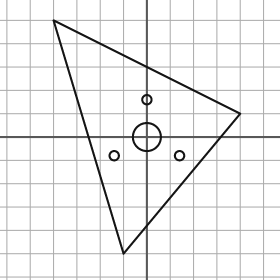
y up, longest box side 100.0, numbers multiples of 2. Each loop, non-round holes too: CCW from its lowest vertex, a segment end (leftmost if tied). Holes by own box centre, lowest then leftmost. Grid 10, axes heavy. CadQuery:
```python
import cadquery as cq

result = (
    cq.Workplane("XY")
    .moveTo(-10.0, -50.0)
    .lineTo(40.0, 10.0)
    .lineTo(-40.0, 50.0)
    .close()
    .moveTo(-14.0, -8.0)
    .circle(2.0)
    .moveTo(14.0, -8.0)
    .circle(2.0)
    .moveTo(0.0, 0.0)
    .circle(6.0)
    .moveTo(0.0, 16.0)
    .circle(2.0)
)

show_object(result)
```